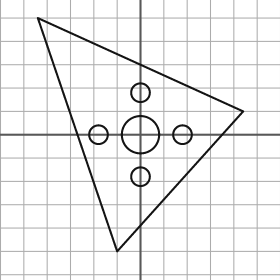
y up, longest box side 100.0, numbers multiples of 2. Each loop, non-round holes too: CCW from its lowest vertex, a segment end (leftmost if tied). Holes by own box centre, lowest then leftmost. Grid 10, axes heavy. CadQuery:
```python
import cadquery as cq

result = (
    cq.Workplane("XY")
    .moveTo(-10.0, -50.0)
    .lineTo(44.0, 10.0)
    .lineTo(-44.0, 50.0)
    .close()
    .moveTo(0.0, -18.0)
    .circle(4.0)
    .moveTo(-18.0, 0.0)
    .circle(4.0)
    .moveTo(0.0, 0.0)
    .circle(8.0)
    .moveTo(18.0, 0.0)
    .circle(4.0)
    .moveTo(0.0, 18.0)
    .circle(4.0)
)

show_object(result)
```